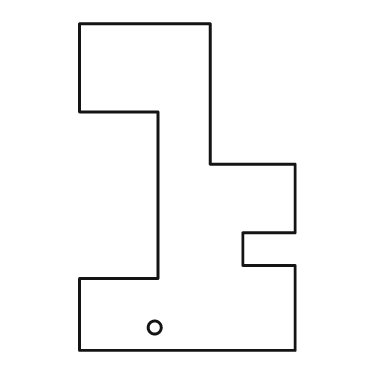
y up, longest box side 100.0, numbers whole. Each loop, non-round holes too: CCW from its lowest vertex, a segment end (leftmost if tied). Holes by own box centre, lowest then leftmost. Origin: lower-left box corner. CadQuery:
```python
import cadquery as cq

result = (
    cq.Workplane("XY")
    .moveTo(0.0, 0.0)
    .lineTo(66.0, 0.0)
    .lineTo(66.0, 26.0)
    .lineTo(50.0, 26.0)
    .lineTo(50.0, 36.0)
    .lineTo(66.0, 36.0)
    .lineTo(66.0, 57.0)
    .lineTo(40.0, 57.0)
    .lineTo(40.0, 100.0)
    .lineTo(0.0, 100.0)
    .lineTo(0.0, 73.0)
    .lineTo(24.0, 73.0)
    .lineTo(24.0, 22.0)
    .lineTo(0.0, 22.0)
    .close()
    .moveTo(23.0, 7.0)
    .circle(2.0)
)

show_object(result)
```